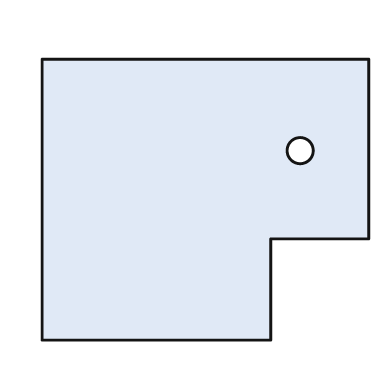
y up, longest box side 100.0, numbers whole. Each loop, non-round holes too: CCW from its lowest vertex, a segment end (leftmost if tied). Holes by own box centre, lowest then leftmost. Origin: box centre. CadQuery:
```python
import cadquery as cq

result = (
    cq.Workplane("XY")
    .moveTo(-50.0, -43.0)
    .lineTo(20.0, -43.0)
    .lineTo(20.0, -12.0)
    .lineTo(50.0, -12.0)
    .lineTo(50.0, 43.0)
    .lineTo(-50.0, 43.0)
    .close()
    .moveTo(29.0, 15.0)
    .circle(4.0)
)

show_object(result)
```